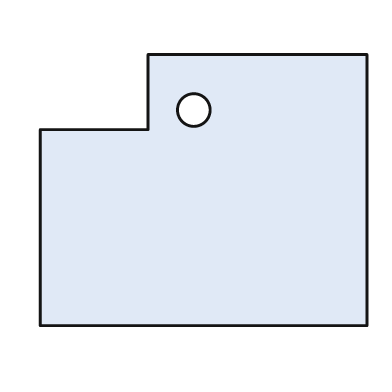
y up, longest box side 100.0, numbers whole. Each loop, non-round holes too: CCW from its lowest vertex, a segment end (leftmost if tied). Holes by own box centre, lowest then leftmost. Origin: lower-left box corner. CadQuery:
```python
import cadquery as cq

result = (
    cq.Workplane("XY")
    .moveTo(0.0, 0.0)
    .lineTo(100.0, 0.0)
    .lineTo(100.0, 83.0)
    .lineTo(33.0, 83.0)
    .lineTo(33.0, 60.0)
    .lineTo(0.0, 60.0)
    .close()
    .moveTo(47.0, 66.0)
    .circle(5.0)
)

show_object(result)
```